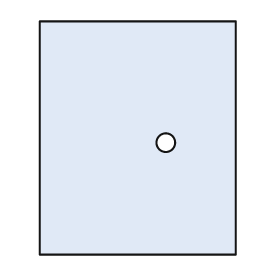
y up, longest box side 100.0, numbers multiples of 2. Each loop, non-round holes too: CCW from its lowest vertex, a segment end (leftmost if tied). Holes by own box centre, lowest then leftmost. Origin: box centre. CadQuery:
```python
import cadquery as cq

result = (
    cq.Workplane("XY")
    .moveTo(-42.0, -50.0)
    .lineTo(42.0, -50.0)
    .lineTo(42.0, 50.0)
    .lineTo(-42.0, 50.0)
    .close()
    .moveTo(12.0, -2.0)
    .circle(4.0)
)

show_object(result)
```